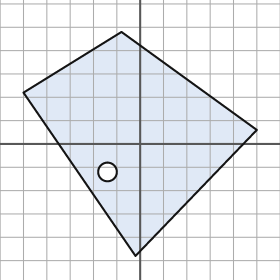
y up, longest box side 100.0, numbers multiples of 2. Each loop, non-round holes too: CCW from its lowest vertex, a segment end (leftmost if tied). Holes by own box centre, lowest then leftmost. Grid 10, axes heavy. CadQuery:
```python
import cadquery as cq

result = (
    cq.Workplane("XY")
    .moveTo(-2.0, -48.0)
    .lineTo(50.0, 6.0)
    .lineTo(-8.0, 48.0)
    .lineTo(-50.0, 22.0)
    .close()
    .moveTo(-14.0, -12.0)
    .circle(4.0)
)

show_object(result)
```